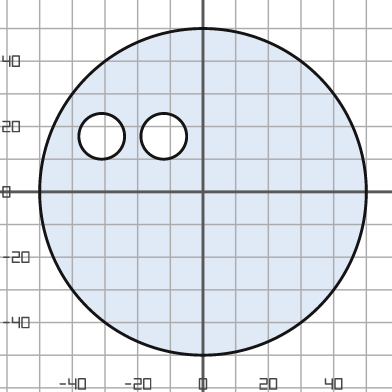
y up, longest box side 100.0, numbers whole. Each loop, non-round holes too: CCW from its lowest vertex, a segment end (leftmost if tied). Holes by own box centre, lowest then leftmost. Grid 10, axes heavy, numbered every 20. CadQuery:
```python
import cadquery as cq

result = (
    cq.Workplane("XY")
    .moveTo(0.0, 0.0)
    .circle(50.0)
    .moveTo(-31.0, 17.0)
    .circle(7.0)
    .moveTo(-12.0, 17.0)
    .circle(7.0)
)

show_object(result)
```